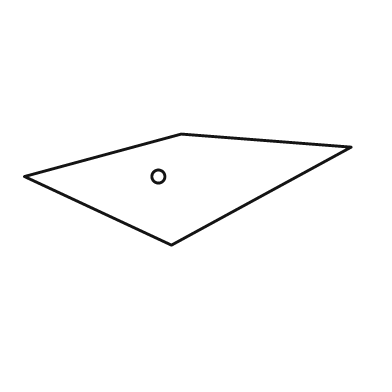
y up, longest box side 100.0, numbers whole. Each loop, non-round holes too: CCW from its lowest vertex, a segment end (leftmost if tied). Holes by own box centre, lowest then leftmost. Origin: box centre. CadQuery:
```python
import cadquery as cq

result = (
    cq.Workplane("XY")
    .moveTo(-5.0, -17.0)
    .lineTo(50.0, 13.0)
    .lineTo(-2.0, 17.0)
    .lineTo(-50.0, 4.0)
    .close()
    .moveTo(-9.0, 4.0)
    .circle(2.0)
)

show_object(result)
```